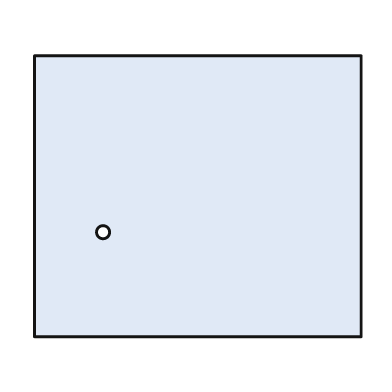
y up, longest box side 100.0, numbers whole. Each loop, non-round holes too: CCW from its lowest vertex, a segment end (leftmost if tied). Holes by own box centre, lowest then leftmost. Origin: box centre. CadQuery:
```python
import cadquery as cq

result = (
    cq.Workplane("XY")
    .moveTo(-50.0, -43.0)
    .lineTo(50.0, -43.0)
    .lineTo(50.0, 43.0)
    .lineTo(-50.0, 43.0)
    .close()
    .moveTo(-29.0, -11.0)
    .circle(2.0)
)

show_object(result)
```